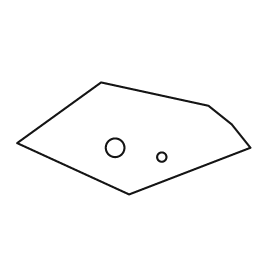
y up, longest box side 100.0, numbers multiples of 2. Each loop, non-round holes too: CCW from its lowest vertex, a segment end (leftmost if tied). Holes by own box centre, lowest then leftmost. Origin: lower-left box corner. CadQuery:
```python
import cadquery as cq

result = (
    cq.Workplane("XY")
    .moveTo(48.0, 0.0)
    .lineTo(100.0, 20.0)
    .lineTo(92.0, 30.0)
    .lineTo(82.0, 38.0)
    .lineTo(36.0, 48.0)
    .lineTo(0.0, 22.0)
    .close()
    .moveTo(62.0, 16.0)
    .circle(2.0)
    .moveTo(42.0, 20.0)
    .circle(4.0)
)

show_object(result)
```